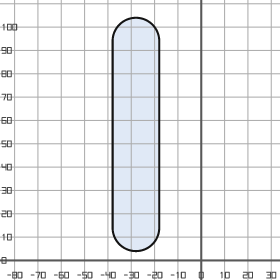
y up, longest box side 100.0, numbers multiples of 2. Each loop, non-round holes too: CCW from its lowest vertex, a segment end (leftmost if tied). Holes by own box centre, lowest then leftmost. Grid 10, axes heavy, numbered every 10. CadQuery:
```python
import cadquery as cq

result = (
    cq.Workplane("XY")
    .moveTo(-38.0, 14.0)
    .threePointArc((-28.0, 4.0), (-18.0, 14.0))
    .lineTo(-18.0, 94.0)
    .threePointArc((-28.0, 104.0), (-38.0, 94.0))
    .close()
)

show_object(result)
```